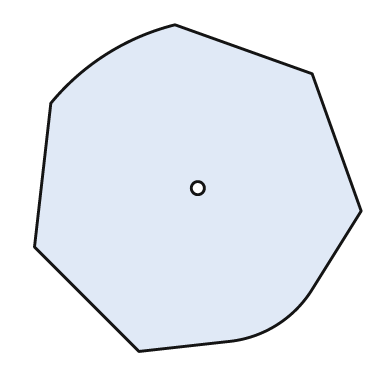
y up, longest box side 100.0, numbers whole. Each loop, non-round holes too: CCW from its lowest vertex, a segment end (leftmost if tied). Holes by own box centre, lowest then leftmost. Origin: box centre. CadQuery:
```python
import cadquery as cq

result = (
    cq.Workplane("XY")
    .moveTo(-18.0, -50.0)
    .lineTo(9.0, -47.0)
    .threePointArc((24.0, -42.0), (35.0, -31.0))
    .lineTo(50.0, -7.0)
    .lineTo(35.0, 35.0)
    .lineTo(-7.0, 50.0)
    .threePointArc((-28.0, 41.0), (-45.0, 26.0))
    .lineTo(-50.0, -18.0)
    .close()
    .moveTo(0.0, 0.0)
    .circle(2.0)
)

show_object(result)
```